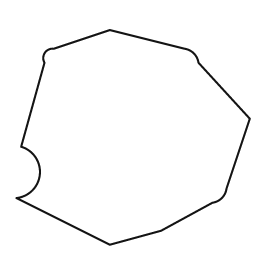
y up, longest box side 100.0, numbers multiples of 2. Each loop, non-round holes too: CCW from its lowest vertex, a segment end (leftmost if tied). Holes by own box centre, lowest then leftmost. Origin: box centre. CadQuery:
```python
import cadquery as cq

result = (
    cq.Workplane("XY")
    .moveTo(-10.0, -46.0)
    .lineTo(12.0, -40.0)
    .lineTo(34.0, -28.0)
    .threePointArc((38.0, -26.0), (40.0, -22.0))
    .lineTo(50.0, 8.0)
    .lineTo(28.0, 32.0)
    .threePointArc((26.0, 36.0), (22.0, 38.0))
    .lineTo(-10.0, 46.0)
    .lineTo(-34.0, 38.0)
    .threePointArc((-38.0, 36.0), (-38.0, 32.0))
    .lineTo(-48.0, -4.0)
    .threePointArc((-40.0, -16.0), (-50.0, -26.0))
    .close()
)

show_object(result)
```